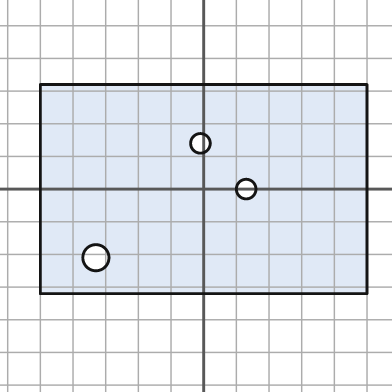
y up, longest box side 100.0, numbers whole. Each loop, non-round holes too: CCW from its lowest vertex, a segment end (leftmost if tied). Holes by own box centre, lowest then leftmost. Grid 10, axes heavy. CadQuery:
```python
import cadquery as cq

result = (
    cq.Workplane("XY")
    .moveTo(-50.0, -32.0)
    .lineTo(50.0, -32.0)
    .lineTo(50.0, 32.0)
    .lineTo(-50.0, 32.0)
    .close()
    .moveTo(-33.0, -21.0)
    .circle(4.0)
    .moveTo(13.0, 0.0)
    .circle(3.0)
    .moveTo(-1.0, 14.0)
    .circle(3.0)
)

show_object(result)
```